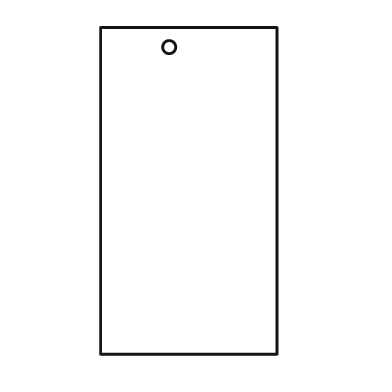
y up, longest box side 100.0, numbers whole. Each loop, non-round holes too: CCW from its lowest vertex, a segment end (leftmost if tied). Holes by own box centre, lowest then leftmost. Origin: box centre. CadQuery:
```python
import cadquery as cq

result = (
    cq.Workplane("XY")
    .moveTo(-27.0, -50.0)
    .lineTo(27.0, -50.0)
    .lineTo(27.0, 50.0)
    .lineTo(-27.0, 50.0)
    .close()
    .moveTo(-6.0, 44.0)
    .circle(2.0)
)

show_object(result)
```